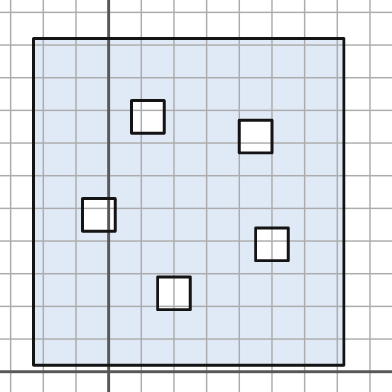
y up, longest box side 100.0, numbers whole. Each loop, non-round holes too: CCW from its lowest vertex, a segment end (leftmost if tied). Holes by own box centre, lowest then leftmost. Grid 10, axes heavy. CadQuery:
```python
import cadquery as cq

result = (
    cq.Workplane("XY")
    .moveTo(-23.0, 2.0)
    .lineTo(72.0, 2.0)
    .lineTo(72.0, 102.0)
    .lineTo(-23.0, 102.0)
    .close()
    .moveTo(15.0, 19.0)
    .lineTo(25.0, 19.0)
    .lineTo(25.0, 29.0)
    .lineTo(15.0, 29.0)
    .close()
    .moveTo(45.0, 34.0)
    .lineTo(55.0, 34.0)
    .lineTo(55.0, 44.0)
    .lineTo(45.0, 44.0)
    .close()
    .moveTo(-8.0, 43.0)
    .lineTo(2.0, 43.0)
    .lineTo(2.0, 53.0)
    .lineTo(-8.0, 53.0)
    .close()
    .moveTo(40.0, 67.0)
    .lineTo(50.0, 67.0)
    .lineTo(50.0, 77.0)
    .lineTo(40.0, 77.0)
    .close()
    .moveTo(7.0, 73.0)
    .lineTo(17.0, 73.0)
    .lineTo(17.0, 83.0)
    .lineTo(7.0, 83.0)
    .close()
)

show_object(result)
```